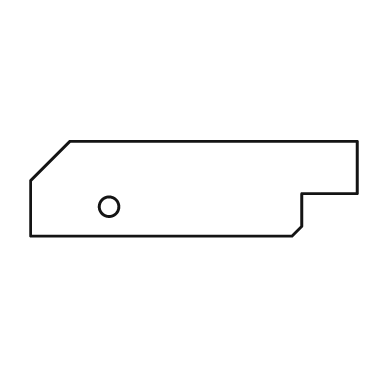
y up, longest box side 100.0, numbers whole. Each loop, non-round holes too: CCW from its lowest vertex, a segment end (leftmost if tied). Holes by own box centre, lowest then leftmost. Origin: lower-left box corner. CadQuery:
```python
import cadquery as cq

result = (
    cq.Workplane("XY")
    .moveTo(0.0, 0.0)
    .lineTo(80.0, 0.0)
    .lineTo(83.0, 3.0)
    .lineTo(83.0, 13.0)
    .lineTo(100.0, 13.0)
    .lineTo(100.0, 29.0)
    .lineTo(12.0, 29.0)
    .lineTo(0.0, 17.0)
    .close()
    .moveTo(24.0, 9.0)
    .circle(3.0)
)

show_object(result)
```